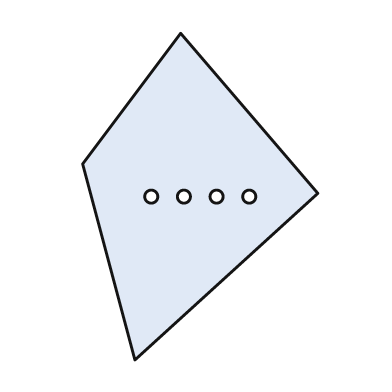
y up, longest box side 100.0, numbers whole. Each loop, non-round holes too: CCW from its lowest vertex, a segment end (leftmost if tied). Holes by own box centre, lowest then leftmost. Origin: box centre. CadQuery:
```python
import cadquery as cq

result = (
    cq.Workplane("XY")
    .moveTo(-20.0, -50.0)
    .lineTo(36.0, 1.0)
    .lineTo(-6.0, 50.0)
    .lineTo(-36.0, 10.0)
    .close()
    .moveTo(-15.0, 0.0)
    .circle(2.0)
    .moveTo(-5.0, 0.0)
    .circle(2.0)
    .moveTo(5.0, 0.0)
    .circle(2.0)
    .moveTo(15.0, 0.0)
    .circle(2.0)
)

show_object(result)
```